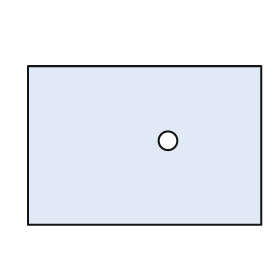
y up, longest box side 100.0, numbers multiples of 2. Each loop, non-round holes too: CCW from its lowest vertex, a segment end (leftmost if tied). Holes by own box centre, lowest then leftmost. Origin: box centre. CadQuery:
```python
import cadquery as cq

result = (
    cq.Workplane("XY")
    .moveTo(-50.0, -34.0)
    .lineTo(50.0, -34.0)
    .lineTo(50.0, 34.0)
    .lineTo(-50.0, 34.0)
    .close()
    .moveTo(10.0, 2.0)
    .circle(4.0)
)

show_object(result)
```